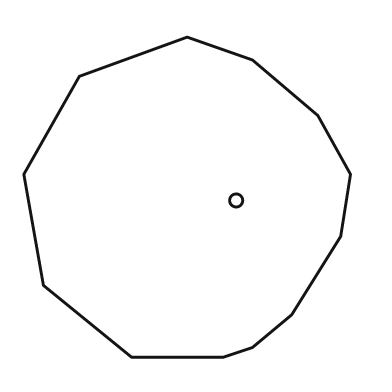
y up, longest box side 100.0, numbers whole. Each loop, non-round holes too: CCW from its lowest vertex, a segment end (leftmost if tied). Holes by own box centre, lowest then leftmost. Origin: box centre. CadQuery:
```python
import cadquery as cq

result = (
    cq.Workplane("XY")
    .moveTo(-17.0, -49.0)
    .lineTo(11.0, -49.0)
    .lineTo(20.0, -46.0)
    .lineTo(32.0, -36.0)
    .lineTo(47.0, -12.0)
    .lineTo(50.0, 7.0)
    .lineTo(40.0, 25.0)
    .lineTo(20.0, 42.0)
    .lineTo(0.0, 49.0)
    .lineTo(-33.0, 37.0)
    .lineTo(-50.0, 7.0)
    .lineTo(-44.0, -27.0)
    .close()
    .moveTo(15.0, -1.0)
    .circle(2.0)
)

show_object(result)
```